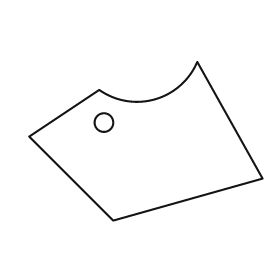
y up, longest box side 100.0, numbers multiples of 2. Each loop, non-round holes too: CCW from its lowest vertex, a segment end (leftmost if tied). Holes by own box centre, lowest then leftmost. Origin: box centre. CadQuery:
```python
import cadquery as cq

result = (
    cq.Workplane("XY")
    .moveTo(-14.0, -34.0)
    .lineTo(50.0, -16.0)
    .lineTo(22.0, 34.0)
    .threePointArc((4.0, 18.0), (-20.0, 22.0))
    .lineTo(-50.0, 2.0)
    .close()
    .moveTo(-18.0, 8.0)
    .circle(4.0)
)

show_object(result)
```